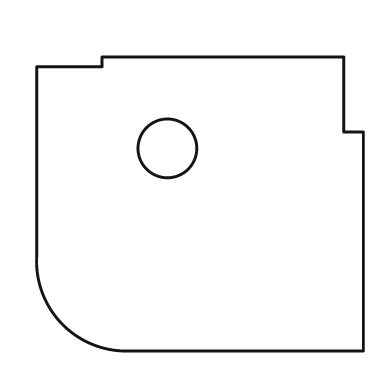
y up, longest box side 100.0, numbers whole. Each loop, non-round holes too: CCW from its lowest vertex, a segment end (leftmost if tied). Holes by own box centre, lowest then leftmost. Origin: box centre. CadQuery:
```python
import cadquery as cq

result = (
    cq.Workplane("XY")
    .moveTo(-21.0, -45.0)
    .lineTo(50.0, -45.0)
    .lineTo(50.0, 22.0)
    .lineTo(44.0, 22.0)
    .lineTo(44.0, 45.0)
    .lineTo(-30.0, 45.0)
    .lineTo(-30.0, 42.0)
    .lineTo(-50.0, 42.0)
    .lineTo(-50.0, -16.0)
    .threePointArc((-42.0, -37.0), (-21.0, -45.0))
    .close()
    .moveTo(-10.0, 17.0)
    .circle(9.0)
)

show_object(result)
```